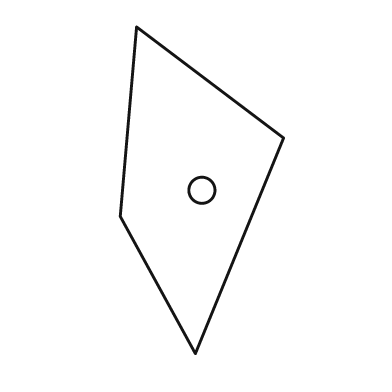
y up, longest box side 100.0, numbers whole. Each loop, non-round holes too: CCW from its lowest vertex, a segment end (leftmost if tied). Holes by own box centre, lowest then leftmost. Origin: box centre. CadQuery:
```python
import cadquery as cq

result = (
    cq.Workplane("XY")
    .moveTo(-2.0, -50.0)
    .lineTo(25.0, 16.0)
    .lineTo(-20.0, 50.0)
    .lineTo(-25.0, -8.0)
    .close()
    .moveTo(0.0, 0.0)
    .circle(4.0)
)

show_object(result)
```